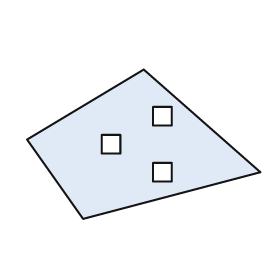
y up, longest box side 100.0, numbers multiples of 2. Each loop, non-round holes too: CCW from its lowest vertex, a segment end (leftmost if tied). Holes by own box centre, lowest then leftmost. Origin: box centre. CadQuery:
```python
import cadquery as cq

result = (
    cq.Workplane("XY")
    .moveTo(-26.0, -32.0)
    .lineTo(50.0, -12.0)
    .lineTo(0.0, 32.0)
    .lineTo(-50.0, 2.0)
    .close()
    .moveTo(4.0, -16.0)
    .lineTo(12.0, -16.0)
    .lineTo(12.0, -8.0)
    .lineTo(4.0, -8.0)
    .close()
    .moveTo(-18.0, -4.0)
    .lineTo(-10.0, -4.0)
    .lineTo(-10.0, 4.0)
    .lineTo(-18.0, 4.0)
    .close()
    .moveTo(4.0, 8.0)
    .lineTo(12.0, 8.0)
    .lineTo(12.0, 16.0)
    .lineTo(4.0, 16.0)
    .close()
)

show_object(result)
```